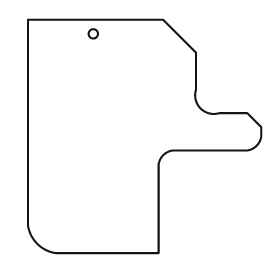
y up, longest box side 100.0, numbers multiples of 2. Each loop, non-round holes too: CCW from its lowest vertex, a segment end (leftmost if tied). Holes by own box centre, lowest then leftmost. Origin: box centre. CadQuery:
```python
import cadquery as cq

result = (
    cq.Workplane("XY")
    .moveTo(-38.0, -50.0)
    .lineTo(6.0, -50.0)
    .lineTo(6.0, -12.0)
    .threePointArc((8.0, -8.0), (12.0, -6.0))
    .lineTo(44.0, -6.0)
    .threePointArc((48.0, -4.0), (50.0, 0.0))
    .lineTo(50.0, 4.0)
    .lineTo(44.0, 10.0)
    .lineTo(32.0, 10.0)
    .threePointArc((24.0, 12.0), (22.0, 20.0))
    .lineTo(22.0, 36.0)
    .lineTo(8.0, 50.0)
    .lineTo(-50.0, 50.0)
    .lineTo(-50.0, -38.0)
    .threePointArc((-46.0, -46.0), (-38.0, -50.0))
    .close()
    .moveTo(-22.0, 44.0)
    .circle(2.0)
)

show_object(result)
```